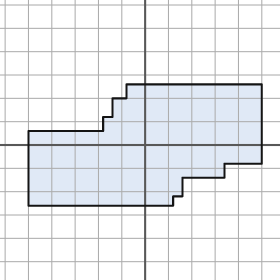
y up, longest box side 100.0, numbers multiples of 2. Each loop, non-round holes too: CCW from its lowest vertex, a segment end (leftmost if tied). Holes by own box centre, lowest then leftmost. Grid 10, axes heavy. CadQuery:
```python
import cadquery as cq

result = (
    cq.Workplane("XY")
    .moveTo(-50.0, -26.0)
    .lineTo(12.0, -26.0)
    .lineTo(12.0, -22.0)
    .lineTo(16.0, -22.0)
    .lineTo(16.0, -14.0)
    .lineTo(34.0, -14.0)
    .lineTo(34.0, -8.0)
    .lineTo(50.0, -8.0)
    .lineTo(50.0, 26.0)
    .lineTo(-8.0, 26.0)
    .lineTo(-8.0, 20.0)
    .lineTo(-14.0, 20.0)
    .lineTo(-14.0, 12.0)
    .lineTo(-18.0, 12.0)
    .lineTo(-18.0, 6.0)
    .lineTo(-50.0, 6.0)
    .close()
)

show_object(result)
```